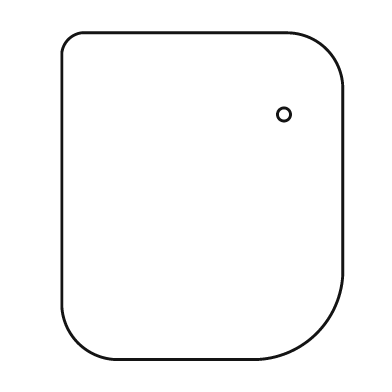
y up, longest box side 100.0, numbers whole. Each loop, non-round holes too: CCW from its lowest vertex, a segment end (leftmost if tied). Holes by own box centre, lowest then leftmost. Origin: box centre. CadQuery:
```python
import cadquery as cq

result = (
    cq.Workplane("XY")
    .moveTo(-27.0, -50.0)
    .lineTo(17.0, -50.0)
    .threePointArc((35.0, -42.0), (43.0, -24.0))
    .lineTo(43.0, 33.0)
    .threePointArc((38.0, 45.0), (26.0, 50.0))
    .lineTo(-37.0, 50.0)
    .threePointArc((-41.0, 48.0), (-43.0, 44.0))
    .lineTo(-43.0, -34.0)
    .threePointArc((-38.0, -45.0), (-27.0, -50.0))
    .close()
    .moveTo(25.0, 25.0)
    .circle(2.0)
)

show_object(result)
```